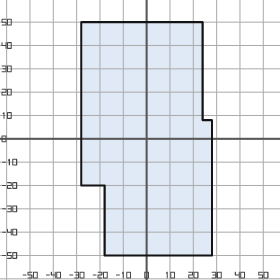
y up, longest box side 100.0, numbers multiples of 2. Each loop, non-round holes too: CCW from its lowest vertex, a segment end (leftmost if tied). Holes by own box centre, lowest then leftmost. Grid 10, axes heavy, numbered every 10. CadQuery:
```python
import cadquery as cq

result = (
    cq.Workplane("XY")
    .moveTo(-18.0, -50.0)
    .lineTo(28.0, -50.0)
    .lineTo(28.0, 8.0)
    .lineTo(24.0, 8.0)
    .lineTo(24.0, 50.0)
    .lineTo(-28.0, 50.0)
    .lineTo(-28.0, -20.0)
    .lineTo(-18.0, -20.0)
    .close()
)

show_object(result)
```